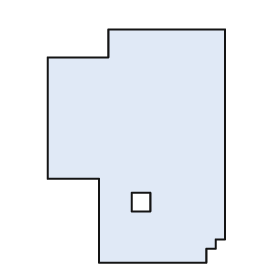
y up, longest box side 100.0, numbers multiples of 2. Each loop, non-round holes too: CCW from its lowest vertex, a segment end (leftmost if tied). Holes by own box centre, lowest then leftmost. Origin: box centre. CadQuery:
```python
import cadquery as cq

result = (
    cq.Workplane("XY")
    .moveTo(-16.0, -50.0)
    .lineTo(30.0, -50.0)
    .lineTo(30.0, -44.0)
    .lineTo(34.0, -44.0)
    .lineTo(34.0, -40.0)
    .lineTo(38.0, -40.0)
    .lineTo(38.0, 50.0)
    .lineTo(-12.0, 50.0)
    .lineTo(-12.0, 38.0)
    .lineTo(-38.0, 38.0)
    .lineTo(-38.0, -14.0)
    .lineTo(-16.0, -14.0)
    .close()
    .moveTo(-2.0, -28.0)
    .lineTo(6.0, -28.0)
    .lineTo(6.0, -20.0)
    .lineTo(-2.0, -20.0)
    .close()
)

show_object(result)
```